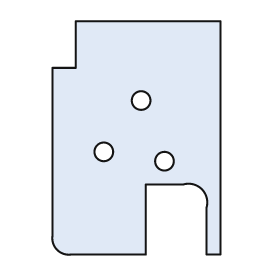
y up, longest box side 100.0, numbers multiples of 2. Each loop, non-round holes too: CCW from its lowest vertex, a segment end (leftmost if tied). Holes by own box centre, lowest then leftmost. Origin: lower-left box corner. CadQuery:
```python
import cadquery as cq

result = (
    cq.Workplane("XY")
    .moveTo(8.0, 0.0)
    .lineTo(40.0, 0.0)
    .lineTo(40.0, 30.0)
    .lineTo(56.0, 30.0)
    .threePointArc((64.0, 28.0), (66.0, 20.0))
    .lineTo(66.0, 0.0)
    .lineTo(72.0, 0.0)
    .lineTo(72.0, 100.0)
    .lineTo(10.0, 100.0)
    .lineTo(10.0, 80.0)
    .lineTo(0.0, 80.0)
    .lineTo(0.0, 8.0)
    .threePointArc((2.0, 2.0), (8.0, 0.0))
    .close()
    .moveTo(48.0, 40.0)
    .circle(4.0)
    .moveTo(22.0, 44.0)
    .circle(4.0)
    .moveTo(38.0, 66.0)
    .circle(4.0)
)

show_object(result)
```